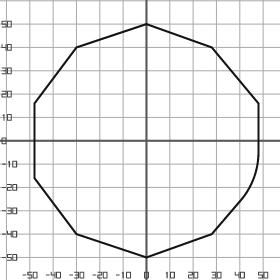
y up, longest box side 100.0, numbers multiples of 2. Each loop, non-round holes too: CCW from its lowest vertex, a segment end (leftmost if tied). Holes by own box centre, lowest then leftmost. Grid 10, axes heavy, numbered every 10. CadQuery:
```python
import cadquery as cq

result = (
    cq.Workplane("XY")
    .moveTo(0.0, -50.0)
    .lineTo(28.0, -40.0)
    .lineTo(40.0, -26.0)
    .threePointArc((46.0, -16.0), (48.0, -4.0))
    .lineTo(48.0, 16.0)
    .lineTo(28.0, 40.0)
    .lineTo(0.0, 50.0)
    .lineTo(-30.0, 40.0)
    .lineTo(-48.0, 16.0)
    .lineTo(-48.0, -16.0)
    .lineTo(-30.0, -40.0)
    .close()
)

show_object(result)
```